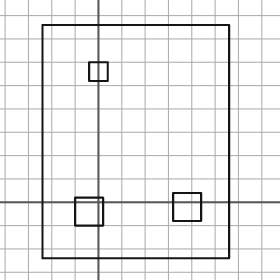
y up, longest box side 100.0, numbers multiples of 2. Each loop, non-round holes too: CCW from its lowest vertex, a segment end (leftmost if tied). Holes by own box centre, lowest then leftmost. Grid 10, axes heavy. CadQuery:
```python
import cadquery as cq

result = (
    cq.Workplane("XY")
    .moveTo(-24.0, -24.0)
    .lineTo(56.0, -24.0)
    .lineTo(56.0, 76.0)
    .lineTo(-24.0, 76.0)
    .close()
    .moveTo(-10.0, -10.0)
    .lineTo(2.0, -10.0)
    .lineTo(2.0, 2.0)
    .lineTo(-10.0, 2.0)
    .close()
    .moveTo(32.0, -8.0)
    .lineTo(44.0, -8.0)
    .lineTo(44.0, 4.0)
    .lineTo(32.0, 4.0)
    .close()
    .moveTo(-4.0, 52.0)
    .lineTo(4.0, 52.0)
    .lineTo(4.0, 60.0)
    .lineTo(-4.0, 60.0)
    .close()
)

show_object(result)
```